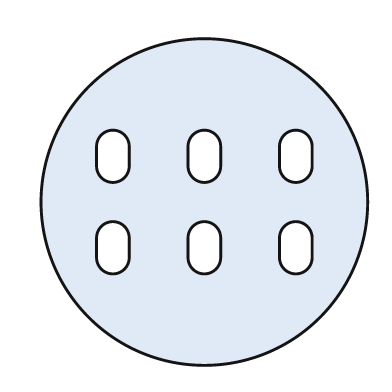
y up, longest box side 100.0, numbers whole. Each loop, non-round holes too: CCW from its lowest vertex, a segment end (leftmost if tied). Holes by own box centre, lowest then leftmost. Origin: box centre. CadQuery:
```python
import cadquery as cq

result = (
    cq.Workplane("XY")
    .moveTo(0.0, 0.0)
    .circle(50.0)
    .moveTo(-33.0, -17.0)
    .threePointArc((-28.0, -22.0), (-23.0, -17.0))
    .lineTo(-23.0, -11.0)
    .threePointArc((-28.0, -6.0), (-33.0, -11.0))
    .close()
    .moveTo(-5.0, -17.0)
    .threePointArc((0.0, -22.0), (5.0, -17.0))
    .lineTo(5.0, -11.0)
    .threePointArc((0.0, -6.0), (-5.0, -11.0))
    .close()
    .moveTo(23.0, -17.0)
    .threePointArc((28.0, -22.0), (33.0, -17.0))
    .lineTo(33.0, -11.0)
    .threePointArc((28.0, -6.0), (23.0, -11.0))
    .close()
    .moveTo(-33.0, 11.0)
    .threePointArc((-28.0, 6.0), (-23.0, 11.0))
    .lineTo(-23.0, 17.0)
    .threePointArc((-28.0, 22.0), (-33.0, 17.0))
    .close()
    .moveTo(-5.0, 11.0)
    .threePointArc((0.0, 6.0), (5.0, 11.0))
    .lineTo(5.0, 17.0)
    .threePointArc((0.0, 22.0), (-5.0, 17.0))
    .close()
    .moveTo(23.0, 11.0)
    .threePointArc((28.0, 6.0), (33.0, 11.0))
    .lineTo(33.0, 17.0)
    .threePointArc((28.0, 22.0), (23.0, 17.0))
    .close()
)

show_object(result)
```